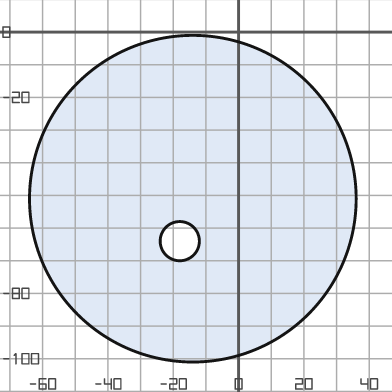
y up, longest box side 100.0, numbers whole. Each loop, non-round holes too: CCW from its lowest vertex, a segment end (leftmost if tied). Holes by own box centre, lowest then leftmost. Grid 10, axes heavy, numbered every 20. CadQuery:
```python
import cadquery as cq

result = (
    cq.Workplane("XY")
    .moveTo(-14.0, -51.0)
    .circle(50.0)
    .moveTo(-18.0, -64.0)
    .circle(6.0)
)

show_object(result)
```